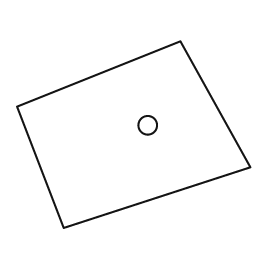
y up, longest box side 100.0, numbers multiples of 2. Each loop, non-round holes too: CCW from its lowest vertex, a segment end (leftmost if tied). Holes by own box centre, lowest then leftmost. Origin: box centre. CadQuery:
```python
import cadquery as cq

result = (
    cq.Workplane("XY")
    .moveTo(-30.0, -40.0)
    .lineTo(50.0, -14.0)
    .lineTo(20.0, 40.0)
    .lineTo(-50.0, 12.0)
    .close()
    .moveTo(6.0, 4.0)
    .circle(4.0)
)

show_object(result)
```